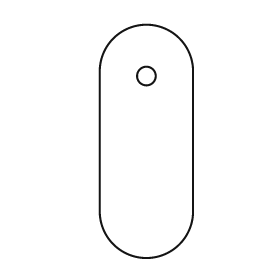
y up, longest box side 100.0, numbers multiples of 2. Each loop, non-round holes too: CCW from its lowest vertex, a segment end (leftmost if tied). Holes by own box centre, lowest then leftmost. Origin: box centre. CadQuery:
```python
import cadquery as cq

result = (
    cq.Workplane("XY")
    .moveTo(-20.0, -30.0)
    .threePointArc((0.0, -50.0), (20.0, -30.0))
    .lineTo(20.0, 30.0)
    .threePointArc((0.0, 50.0), (-20.0, 30.0))
    .close()
    .moveTo(0.0, 28.0)
    .circle(4.0)
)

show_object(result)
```